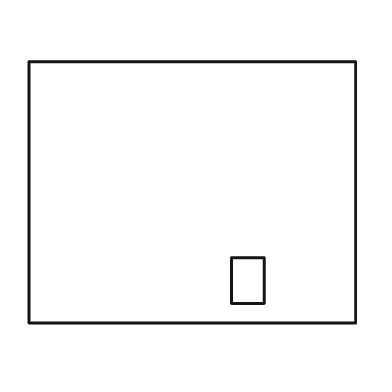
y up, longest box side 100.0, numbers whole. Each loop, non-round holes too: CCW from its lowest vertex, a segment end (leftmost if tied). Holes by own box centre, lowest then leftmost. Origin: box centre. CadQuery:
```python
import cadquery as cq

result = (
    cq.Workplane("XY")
    .moveTo(-50.0, -40.0)
    .lineTo(50.0, -40.0)
    .lineTo(50.0, 40.0)
    .lineTo(-50.0, 40.0)
    .close()
    .moveTo(12.0, -34.0)
    .lineTo(22.0, -34.0)
    .lineTo(22.0, -20.0)
    .lineTo(12.0, -20.0)
    .close()
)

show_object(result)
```